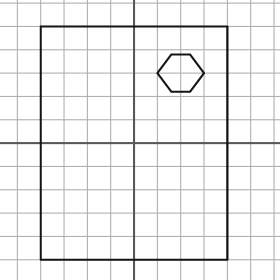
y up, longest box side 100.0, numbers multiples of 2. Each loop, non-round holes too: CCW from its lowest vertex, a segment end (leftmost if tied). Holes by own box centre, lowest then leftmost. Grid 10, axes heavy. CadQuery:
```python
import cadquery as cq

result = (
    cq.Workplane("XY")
    .moveTo(-40.0, -50.0)
    .lineTo(40.0, -50.0)
    .lineTo(40.0, 50.0)
    .lineTo(-40.0, 50.0)
    .close()
    .moveTo(16.0, 22.0)
    .lineTo(24.0, 22.0)
    .lineTo(30.0, 30.0)
    .lineTo(24.0, 38.0)
    .lineTo(16.0, 38.0)
    .lineTo(10.0, 30.0)
    .close()
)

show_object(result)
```